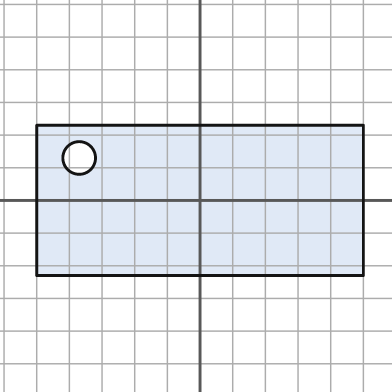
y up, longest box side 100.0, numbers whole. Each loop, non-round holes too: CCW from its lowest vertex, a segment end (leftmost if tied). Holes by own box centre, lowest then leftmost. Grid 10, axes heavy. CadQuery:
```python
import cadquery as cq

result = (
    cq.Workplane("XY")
    .moveTo(-50.0, -23.0)
    .lineTo(50.0, -23.0)
    .lineTo(50.0, 23.0)
    .lineTo(-50.0, 23.0)
    .close()
    .moveTo(-37.0, 13.0)
    .circle(5.0)
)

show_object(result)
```